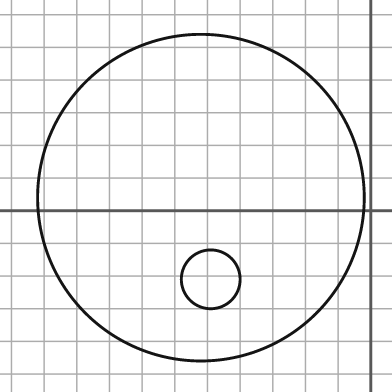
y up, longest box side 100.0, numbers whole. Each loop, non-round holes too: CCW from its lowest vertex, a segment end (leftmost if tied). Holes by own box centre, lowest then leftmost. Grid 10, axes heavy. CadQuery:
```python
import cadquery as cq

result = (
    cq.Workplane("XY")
    .moveTo(-52.0, 4.0)
    .circle(50.0)
    .moveTo(-49.0, -21.0)
    .circle(9.0)
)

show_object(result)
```